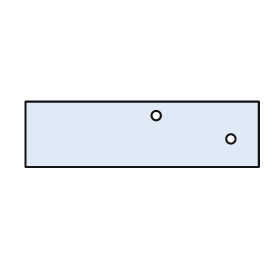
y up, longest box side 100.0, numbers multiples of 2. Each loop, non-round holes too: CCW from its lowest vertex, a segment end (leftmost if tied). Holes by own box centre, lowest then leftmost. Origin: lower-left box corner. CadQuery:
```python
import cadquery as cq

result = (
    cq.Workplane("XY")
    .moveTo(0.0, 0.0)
    .lineTo(100.0, 0.0)
    .lineTo(100.0, 28.0)
    .lineTo(0.0, 28.0)
    .close()
    .moveTo(88.0, 12.0)
    .circle(2.0)
    .moveTo(56.0, 22.0)
    .circle(2.0)
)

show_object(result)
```